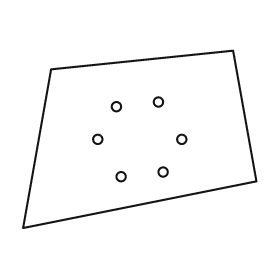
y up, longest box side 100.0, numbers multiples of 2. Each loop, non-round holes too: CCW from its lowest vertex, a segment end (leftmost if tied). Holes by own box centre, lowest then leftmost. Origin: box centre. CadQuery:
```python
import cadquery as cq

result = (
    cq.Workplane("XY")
    .moveTo(-50.0, -38.0)
    .lineTo(50.0, -18.0)
    .lineTo(40.0, 38.0)
    .lineTo(-38.0, 30.0)
    .close()
    .moveTo(-8.0, -16.0)
    .circle(2.0)
    .moveTo(10.0, -14.0)
    .circle(2.0)
    .moveTo(-18.0, 0.0)
    .circle(2.0)
    .moveTo(18.0, 0.0)
    .circle(2.0)
    .moveTo(-10.0, 14.0)
    .circle(2.0)
    .moveTo(8.0, 16.0)
    .circle(2.0)
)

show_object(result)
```